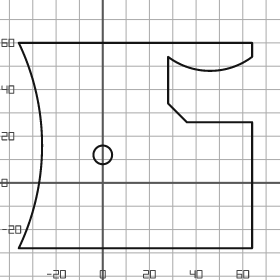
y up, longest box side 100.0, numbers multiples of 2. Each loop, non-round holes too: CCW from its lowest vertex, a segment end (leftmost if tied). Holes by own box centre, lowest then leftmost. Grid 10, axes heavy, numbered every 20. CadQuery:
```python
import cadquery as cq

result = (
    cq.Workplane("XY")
    .moveTo(-36.0, -28.0)
    .lineTo(64.0, -28.0)
    .lineTo(64.0, 26.0)
    .lineTo(36.0, 26.0)
    .lineTo(28.0, 34.0)
    .lineTo(28.0, 54.0)
    .threePointArc((46.0, 48.0), (64.0, 54.0))
    .lineTo(64.0, 60.0)
    .lineTo(-36.0, 60.0)
    .threePointArc((-26.0, 16.0), (-36.0, -28.0))
    .close()
    .moveTo(0.0, 12.0)
    .circle(4.0)
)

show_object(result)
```